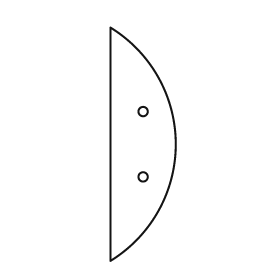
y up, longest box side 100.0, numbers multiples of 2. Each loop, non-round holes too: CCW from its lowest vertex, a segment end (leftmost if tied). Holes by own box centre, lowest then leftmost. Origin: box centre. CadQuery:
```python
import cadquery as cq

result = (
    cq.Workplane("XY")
    .moveTo(-14.0, -50.0)
    .threePointArc((14.0, 0.0), (-14.0, 50.0))
    .close()
    .moveTo(0.0, -14.0)
    .circle(2.0)
    .moveTo(0.0, 14.0)
    .circle(2.0)
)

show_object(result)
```